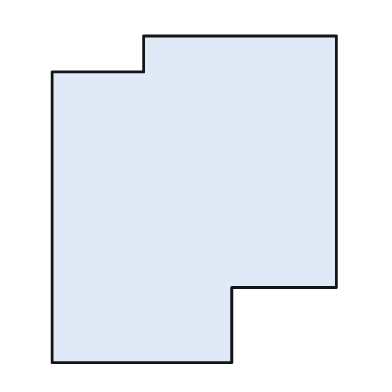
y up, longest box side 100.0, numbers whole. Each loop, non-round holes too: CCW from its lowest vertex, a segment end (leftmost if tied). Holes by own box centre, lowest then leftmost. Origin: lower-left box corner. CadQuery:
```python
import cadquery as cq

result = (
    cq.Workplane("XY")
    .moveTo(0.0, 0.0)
    .lineTo(55.0, 0.0)
    .lineTo(55.0, 23.0)
    .lineTo(87.0, 23.0)
    .lineTo(87.0, 100.0)
    .lineTo(28.0, 100.0)
    .lineTo(28.0, 89.0)
    .lineTo(0.0, 89.0)
    .close()
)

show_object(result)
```